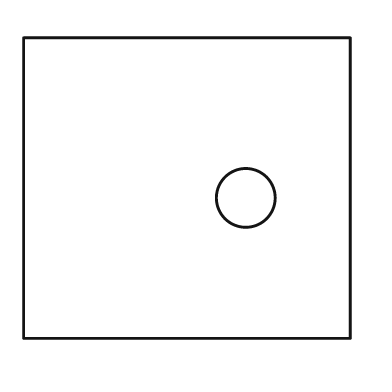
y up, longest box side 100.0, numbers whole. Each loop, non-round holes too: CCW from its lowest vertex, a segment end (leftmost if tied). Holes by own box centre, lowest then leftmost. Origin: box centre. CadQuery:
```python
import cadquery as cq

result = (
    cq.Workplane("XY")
    .moveTo(-50.0, -46.0)
    .lineTo(50.0, -46.0)
    .lineTo(50.0, 46.0)
    .lineTo(-50.0, 46.0)
    .close()
    .moveTo(18.0, -3.0)
    .circle(9.0)
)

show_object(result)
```